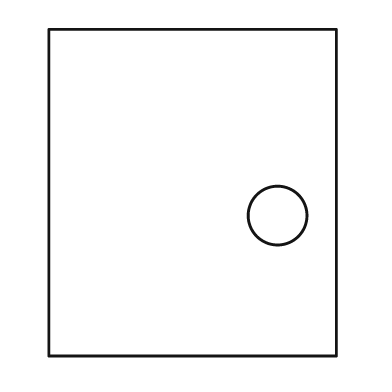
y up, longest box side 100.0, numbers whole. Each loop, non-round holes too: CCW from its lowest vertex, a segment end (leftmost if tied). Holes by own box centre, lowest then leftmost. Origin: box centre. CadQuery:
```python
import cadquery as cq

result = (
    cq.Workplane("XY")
    .moveTo(-44.0, -50.0)
    .lineTo(44.0, -50.0)
    .lineTo(44.0, 50.0)
    .lineTo(-44.0, 50.0)
    .close()
    .moveTo(26.0, -7.0)
    .circle(9.0)
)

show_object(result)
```